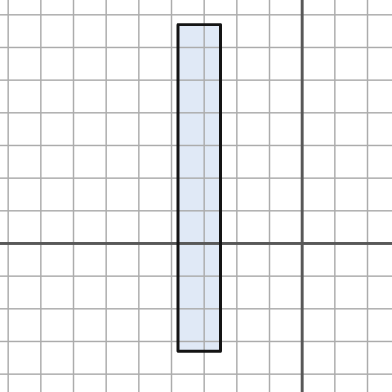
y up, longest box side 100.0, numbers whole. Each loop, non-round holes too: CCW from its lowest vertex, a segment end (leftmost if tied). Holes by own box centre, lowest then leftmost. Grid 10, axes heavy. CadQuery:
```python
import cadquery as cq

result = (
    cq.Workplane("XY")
    .moveTo(-38.0, -33.0)
    .lineTo(-25.0, -33.0)
    .lineTo(-25.0, 67.0)
    .lineTo(-38.0, 67.0)
    .close()
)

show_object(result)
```